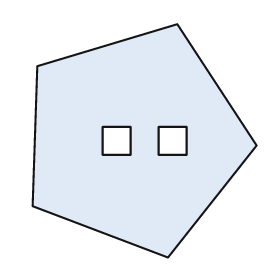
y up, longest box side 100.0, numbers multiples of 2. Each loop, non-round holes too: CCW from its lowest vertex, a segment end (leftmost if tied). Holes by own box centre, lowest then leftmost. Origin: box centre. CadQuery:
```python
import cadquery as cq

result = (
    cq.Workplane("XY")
    .moveTo(10.0, -50.0)
    .lineTo(48.0, -2.0)
    .lineTo(14.0, 50.0)
    .lineTo(-46.0, 32.0)
    .lineTo(-48.0, -28.0)
    .close()
    .moveTo(-18.0, -6.0)
    .lineTo(-6.0, -6.0)
    .lineTo(-6.0, 6.0)
    .lineTo(-18.0, 6.0)
    .close()
    .moveTo(6.0, -6.0)
    .lineTo(18.0, -6.0)
    .lineTo(18.0, 6.0)
    .lineTo(6.0, 6.0)
    .close()
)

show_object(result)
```